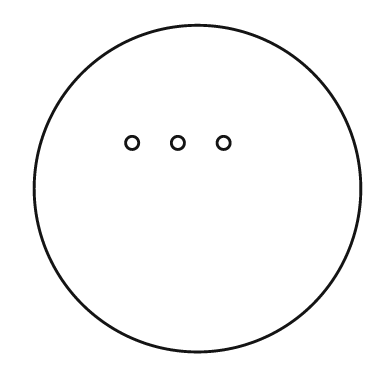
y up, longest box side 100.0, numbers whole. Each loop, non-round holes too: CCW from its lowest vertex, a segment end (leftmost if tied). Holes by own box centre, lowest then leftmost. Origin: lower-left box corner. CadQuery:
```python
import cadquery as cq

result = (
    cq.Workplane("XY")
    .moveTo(50.0, 50.0)
    .circle(50.0)
    .moveTo(30.0, 64.0)
    .circle(2.0)
    .moveTo(44.0, 64.0)
    .circle(2.0)
    .moveTo(58.0, 64.0)
    .circle(2.0)
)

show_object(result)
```